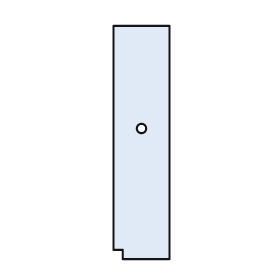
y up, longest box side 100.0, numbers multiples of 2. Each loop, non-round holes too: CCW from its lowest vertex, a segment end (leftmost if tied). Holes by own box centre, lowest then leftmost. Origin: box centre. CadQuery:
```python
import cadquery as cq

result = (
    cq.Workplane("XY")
    .moveTo(-8.0, -50.0)
    .lineTo(12.0, -50.0)
    .lineTo(12.0, 50.0)
    .lineTo(-12.0, 50.0)
    .lineTo(-12.0, -46.0)
    .lineTo(-8.0, -46.0)
    .close()
    .moveTo(0.0, 6.0)
    .circle(2.0)
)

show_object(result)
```